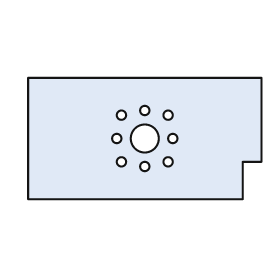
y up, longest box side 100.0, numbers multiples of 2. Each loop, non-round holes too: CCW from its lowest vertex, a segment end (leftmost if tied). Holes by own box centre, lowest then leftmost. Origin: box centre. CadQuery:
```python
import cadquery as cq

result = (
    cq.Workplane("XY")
    .moveTo(-50.0, -26.0)
    .lineTo(42.0, -26.0)
    .lineTo(42.0, -10.0)
    .lineTo(50.0, -10.0)
    .lineTo(50.0, 26.0)
    .lineTo(-50.0, 26.0)
    .close()
    .moveTo(0.0, -12.0)
    .circle(2.0)
    .moveTo(-10.0, -10.0)
    .circle(2.0)
    .moveTo(10.0, -10.0)
    .circle(2.0)
    .moveTo(-12.0, 0.0)
    .circle(2.0)
    .moveTo(0.0, 0.0)
    .circle(6.0)
    .moveTo(12.0, 0.0)
    .circle(2.0)
    .moveTo(-10.0, 10.0)
    .circle(2.0)
    .moveTo(10.0, 10.0)
    .circle(2.0)
    .moveTo(0.0, 12.0)
    .circle(2.0)
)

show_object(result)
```